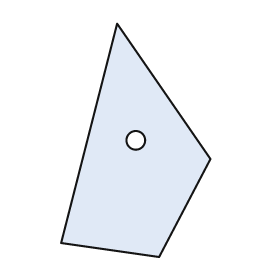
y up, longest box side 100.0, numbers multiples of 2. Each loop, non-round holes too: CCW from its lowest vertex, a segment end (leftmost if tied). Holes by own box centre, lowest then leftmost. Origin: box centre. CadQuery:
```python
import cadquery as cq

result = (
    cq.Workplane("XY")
    .moveTo(10.0, -50.0)
    .lineTo(32.0, -8.0)
    .lineTo(-8.0, 50.0)
    .lineTo(-32.0, -44.0)
    .close()
    .moveTo(0.0, 0.0)
    .circle(4.0)
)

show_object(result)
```